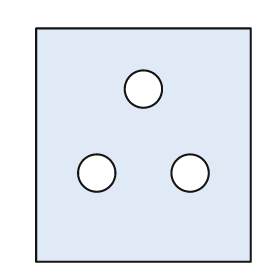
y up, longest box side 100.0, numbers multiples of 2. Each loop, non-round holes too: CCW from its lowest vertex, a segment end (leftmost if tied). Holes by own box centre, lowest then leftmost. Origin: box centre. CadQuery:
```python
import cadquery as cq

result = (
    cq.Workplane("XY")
    .moveTo(-46.0, -50.0)
    .lineTo(46.0, -50.0)
    .lineTo(46.0, 50.0)
    .lineTo(-46.0, 50.0)
    .close()
    .moveTo(-20.0, -12.0)
    .circle(8.0)
    .moveTo(20.0, -12.0)
    .circle(8.0)
    .moveTo(0.0, 24.0)
    .circle(8.0)
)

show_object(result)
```